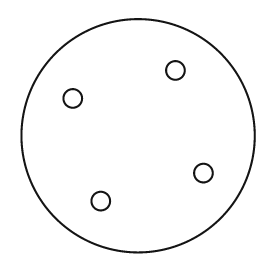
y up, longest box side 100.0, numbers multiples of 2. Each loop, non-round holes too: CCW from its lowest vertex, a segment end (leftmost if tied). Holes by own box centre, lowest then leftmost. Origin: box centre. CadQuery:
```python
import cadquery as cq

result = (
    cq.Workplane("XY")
    .moveTo(0.0, 0.0)
    .circle(50.0)
    .moveTo(-16.0, -28.0)
    .circle(4.0)
    .moveTo(28.0, -16.0)
    .circle(4.0)
    .moveTo(-28.0, 16.0)
    .circle(4.0)
    .moveTo(16.0, 28.0)
    .circle(4.0)
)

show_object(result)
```